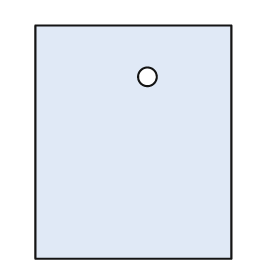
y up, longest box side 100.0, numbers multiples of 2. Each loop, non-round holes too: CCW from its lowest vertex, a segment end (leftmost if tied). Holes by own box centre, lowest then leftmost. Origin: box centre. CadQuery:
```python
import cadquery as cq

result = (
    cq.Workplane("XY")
    .moveTo(-42.0, -50.0)
    .lineTo(42.0, -50.0)
    .lineTo(42.0, 50.0)
    .lineTo(-42.0, 50.0)
    .close()
    .moveTo(6.0, 28.0)
    .circle(4.0)
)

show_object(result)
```